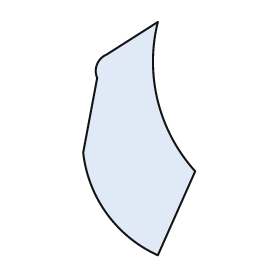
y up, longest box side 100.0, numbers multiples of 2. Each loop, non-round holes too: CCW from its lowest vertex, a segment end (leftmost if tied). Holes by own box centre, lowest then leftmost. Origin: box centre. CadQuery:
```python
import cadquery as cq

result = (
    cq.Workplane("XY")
    .moveTo(8.0, -50.0)
    .lineTo(24.0, -14.0)
    .threePointArc((8.0, 16.0), (8.0, 50.0))
    .lineTo(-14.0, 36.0)
    .threePointArc((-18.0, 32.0), (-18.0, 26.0))
    .lineTo(-24.0, -6.0)
    .threePointArc((-14.0, -32.0), (8.0, -50.0))
    .close()
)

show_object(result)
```